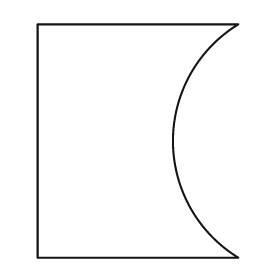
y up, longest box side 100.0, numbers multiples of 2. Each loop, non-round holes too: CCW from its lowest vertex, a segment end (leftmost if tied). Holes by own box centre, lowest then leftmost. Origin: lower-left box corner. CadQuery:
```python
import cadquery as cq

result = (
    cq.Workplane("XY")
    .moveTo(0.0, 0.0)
    .lineTo(86.0, 0.0)
    .threePointArc((58.0, 50.0), (86.0, 100.0))
    .lineTo(0.0, 100.0)
    .close()
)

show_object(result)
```